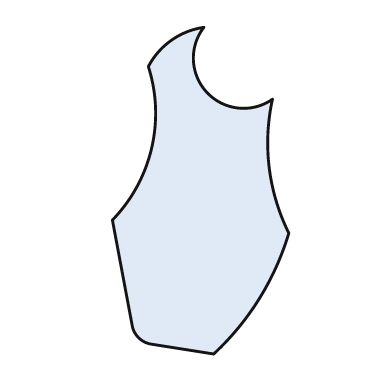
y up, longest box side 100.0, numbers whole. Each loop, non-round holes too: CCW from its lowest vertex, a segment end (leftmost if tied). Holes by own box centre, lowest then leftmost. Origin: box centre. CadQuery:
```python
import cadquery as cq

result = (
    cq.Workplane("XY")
    .moveTo(4.0, -50.0)
    .threePointArc((18.0, -33.0), (27.0, -13.0))
    .threePointArc((21.0, 7.0), (22.0, 28.0))
    .threePointArc((2.0, 30.0), (1.0, 50.0))
    .threePointArc((-9.0, 46.0), (-16.0, 38.0))
    .threePointArc((-15.0, 13.0), (-27.0, -9.0))
    .lineTo(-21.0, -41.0)
    .threePointArc((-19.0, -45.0), (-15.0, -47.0))
    .close()
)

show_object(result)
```